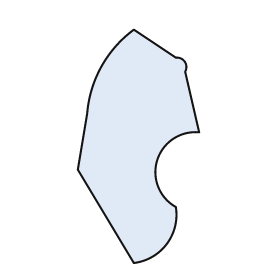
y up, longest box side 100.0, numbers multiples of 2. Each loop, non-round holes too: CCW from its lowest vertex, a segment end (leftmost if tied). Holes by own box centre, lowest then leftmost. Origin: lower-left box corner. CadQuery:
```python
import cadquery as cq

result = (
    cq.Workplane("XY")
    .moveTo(24.0, 0.0)
    .threePointArc((38.0, 8.0), (42.0, 24.0))
    .threePointArc((34.0, 44.0), (52.0, 56.0))
    .lineTo(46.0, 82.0)
    .threePointArc((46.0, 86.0), (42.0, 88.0))
    .lineTo(24.0, 100.0)
    .threePointArc((10.0, 84.0), (4.0, 64.0))
    .lineTo(0.0, 40.0)
    .close()
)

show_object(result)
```